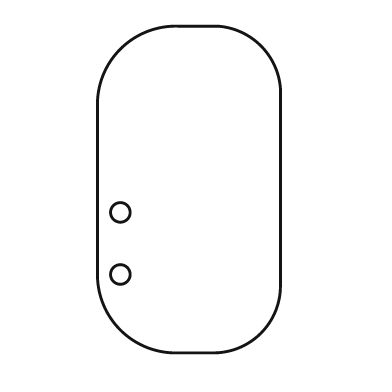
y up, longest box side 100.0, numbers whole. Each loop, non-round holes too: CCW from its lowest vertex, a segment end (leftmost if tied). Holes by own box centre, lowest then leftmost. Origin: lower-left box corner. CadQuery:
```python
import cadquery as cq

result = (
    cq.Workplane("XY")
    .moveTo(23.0, 0.0)
    .lineTo(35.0, 0.0)
    .threePointArc((50.0, 6.0), (56.0, 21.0))
    .lineTo(56.0, 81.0)
    .threePointArc((50.0, 94.0), (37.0, 100.0))
    .lineTo(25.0, 100.0)
    .threePointArc((7.0, 93.0), (0.0, 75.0))
    .lineTo(0.0, 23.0)
    .threePointArc((7.0, 7.0), (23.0, 0.0))
    .close()
    .moveTo(7.0, 24.0)
    .circle(3.0)
    .moveTo(7.0, 43.0)
    .circle(3.0)
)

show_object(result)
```